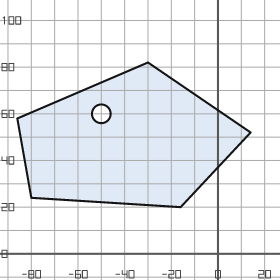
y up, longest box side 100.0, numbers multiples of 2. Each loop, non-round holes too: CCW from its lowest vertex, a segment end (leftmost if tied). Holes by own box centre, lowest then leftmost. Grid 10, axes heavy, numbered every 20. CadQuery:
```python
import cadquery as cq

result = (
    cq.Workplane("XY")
    .moveTo(-16.0, 20.0)
    .lineTo(14.0, 52.0)
    .lineTo(-30.0, 82.0)
    .lineTo(-86.0, 58.0)
    .lineTo(-80.0, 24.0)
    .close()
    .moveTo(-50.0, 60.0)
    .circle(4.0)
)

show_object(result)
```